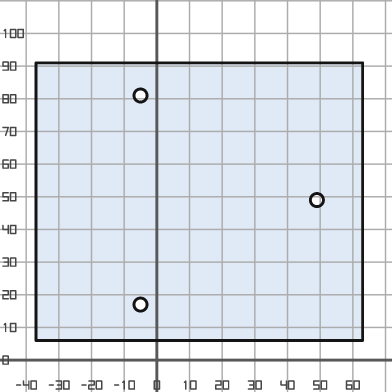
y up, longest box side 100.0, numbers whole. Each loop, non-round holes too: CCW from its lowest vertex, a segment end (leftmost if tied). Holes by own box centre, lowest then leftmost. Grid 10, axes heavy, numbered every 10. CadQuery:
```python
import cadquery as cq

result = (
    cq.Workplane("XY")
    .moveTo(-37.0, 6.0)
    .lineTo(63.0, 6.0)
    .lineTo(63.0, 91.0)
    .lineTo(-37.0, 91.0)
    .close()
    .moveTo(-5.0, 17.0)
    .circle(2.0)
    .moveTo(49.0, 49.0)
    .circle(2.0)
    .moveTo(-5.0, 81.0)
    .circle(2.0)
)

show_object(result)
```